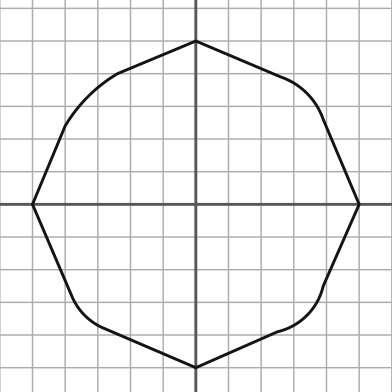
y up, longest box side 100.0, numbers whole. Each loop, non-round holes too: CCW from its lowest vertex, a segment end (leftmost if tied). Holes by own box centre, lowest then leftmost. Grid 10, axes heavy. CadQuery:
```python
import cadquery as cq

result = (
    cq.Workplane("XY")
    .moveTo(0.0, -50.0)
    .lineTo(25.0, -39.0)
    .threePointArc((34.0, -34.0), (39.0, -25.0))
    .lineTo(50.0, 0.0)
    .lineTo(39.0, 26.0)
    .threePointArc((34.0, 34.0), (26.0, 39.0))
    .lineTo(0.0, 50.0)
    .lineTo(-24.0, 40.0)
    .threePointArc((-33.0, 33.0), (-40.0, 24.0))
    .lineTo(-50.0, 0.0)
    .lineTo(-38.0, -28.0)
    .threePointArc((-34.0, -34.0), (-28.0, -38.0))
    .close()
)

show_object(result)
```